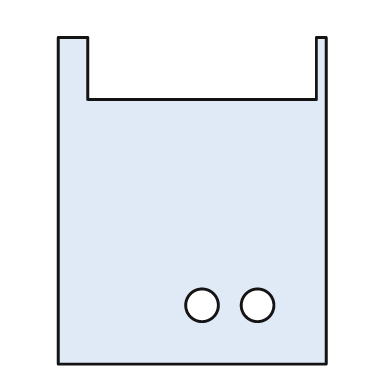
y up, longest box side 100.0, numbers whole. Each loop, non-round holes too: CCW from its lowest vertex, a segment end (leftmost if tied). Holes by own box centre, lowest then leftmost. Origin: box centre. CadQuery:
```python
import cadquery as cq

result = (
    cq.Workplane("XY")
    .moveTo(-41.0, -50.0)
    .lineTo(41.0, -50.0)
    .lineTo(41.0, 50.0)
    .lineTo(38.0, 50.0)
    .lineTo(38.0, 31.0)
    .lineTo(-32.0, 31.0)
    .lineTo(-32.0, 50.0)
    .lineTo(-41.0, 50.0)
    .close()
    .moveTo(3.0, -32.0)
    .circle(5.0)
    .moveTo(20.0, -32.0)
    .circle(5.0)
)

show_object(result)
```